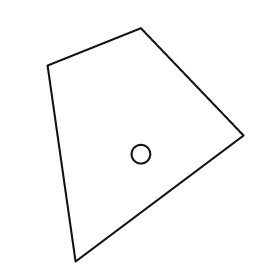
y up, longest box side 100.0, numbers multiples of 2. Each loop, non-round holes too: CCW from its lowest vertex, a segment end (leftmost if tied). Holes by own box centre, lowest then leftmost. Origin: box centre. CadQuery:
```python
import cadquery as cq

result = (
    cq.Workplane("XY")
    .moveTo(-30.0, -50.0)
    .lineTo(42.0, 4.0)
    .lineTo(-2.0, 50.0)
    .lineTo(-42.0, 34.0)
    .close()
    .moveTo(-2.0, -4.0)
    .circle(4.0)
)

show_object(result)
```